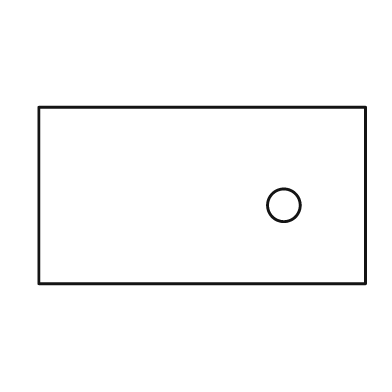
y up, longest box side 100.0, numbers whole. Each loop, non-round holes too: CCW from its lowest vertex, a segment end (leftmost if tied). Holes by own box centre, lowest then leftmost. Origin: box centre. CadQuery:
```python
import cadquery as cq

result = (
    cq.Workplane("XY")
    .moveTo(-50.0, -27.0)
    .lineTo(50.0, -27.0)
    .lineTo(50.0, 27.0)
    .lineTo(-50.0, 27.0)
    .close()
    .moveTo(25.0, -3.0)
    .circle(5.0)
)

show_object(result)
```